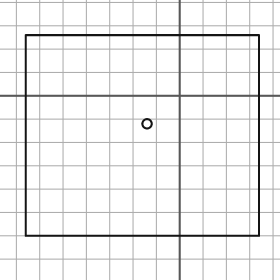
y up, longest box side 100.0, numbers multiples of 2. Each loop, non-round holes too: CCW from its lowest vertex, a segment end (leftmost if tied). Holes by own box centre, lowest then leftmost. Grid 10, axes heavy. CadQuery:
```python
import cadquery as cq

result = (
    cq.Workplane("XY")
    .moveTo(-66.0, -60.0)
    .lineTo(34.0, -60.0)
    .lineTo(34.0, 26.0)
    .lineTo(-66.0, 26.0)
    .close()
    .moveTo(-14.0, -12.0)
    .circle(2.0)
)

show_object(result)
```